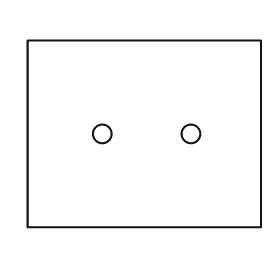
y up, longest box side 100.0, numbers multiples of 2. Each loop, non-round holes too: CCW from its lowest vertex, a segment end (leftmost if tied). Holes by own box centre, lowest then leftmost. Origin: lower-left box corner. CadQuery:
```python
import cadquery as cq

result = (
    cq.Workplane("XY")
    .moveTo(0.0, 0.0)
    .lineTo(100.0, 0.0)
    .lineTo(100.0, 80.0)
    .lineTo(0.0, 80.0)
    .close()
    .moveTo(32.0, 40.0)
    .circle(4.0)
    .moveTo(70.0, 40.0)
    .circle(4.0)
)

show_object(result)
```